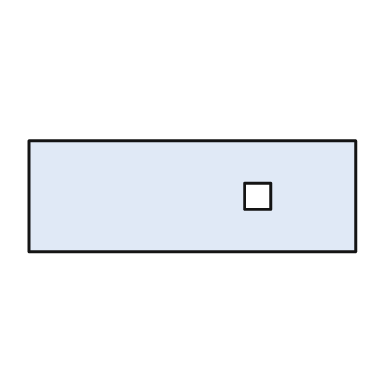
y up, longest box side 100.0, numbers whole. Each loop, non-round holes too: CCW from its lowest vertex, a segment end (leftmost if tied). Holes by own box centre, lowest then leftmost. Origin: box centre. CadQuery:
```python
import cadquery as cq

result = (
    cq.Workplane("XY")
    .moveTo(-50.0, -17.0)
    .lineTo(50.0, -17.0)
    .lineTo(50.0, 17.0)
    .lineTo(-50.0, 17.0)
    .close()
    .moveTo(16.0, -4.0)
    .lineTo(24.0, -4.0)
    .lineTo(24.0, 4.0)
    .lineTo(16.0, 4.0)
    .close()
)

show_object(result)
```